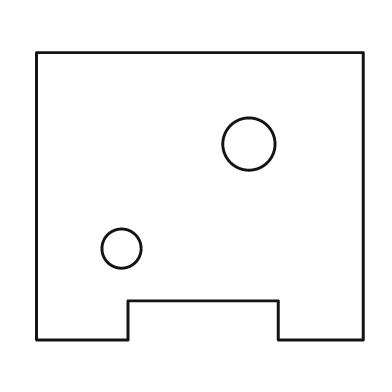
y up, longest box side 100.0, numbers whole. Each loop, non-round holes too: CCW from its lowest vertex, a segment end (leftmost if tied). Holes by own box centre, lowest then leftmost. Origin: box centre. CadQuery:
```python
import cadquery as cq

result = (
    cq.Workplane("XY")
    .moveTo(-50.0, -44.0)
    .lineTo(-22.0, -44.0)
    .lineTo(-22.0, -32.0)
    .lineTo(24.0, -32.0)
    .lineTo(24.0, -44.0)
    .lineTo(50.0, -44.0)
    .lineTo(50.0, 44.0)
    .lineTo(-50.0, 44.0)
    .close()
    .moveTo(-24.0, -16.0)
    .circle(6.0)
    .moveTo(15.0, 16.0)
    .circle(8.0)
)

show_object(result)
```